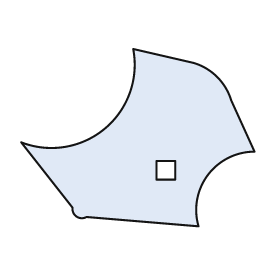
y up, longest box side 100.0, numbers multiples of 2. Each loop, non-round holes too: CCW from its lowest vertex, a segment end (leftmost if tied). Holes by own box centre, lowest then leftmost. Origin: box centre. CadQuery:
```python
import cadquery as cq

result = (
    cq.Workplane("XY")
    .moveTo(26.0, -38.0)
    .threePointArc((30.0, -16.0), (50.0, -6.0))
    .lineTo(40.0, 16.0)
    .threePointArc((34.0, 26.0), (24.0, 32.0))
    .lineTo(-2.0, 38.0)
    .threePointArc((-14.0, 4.0), (-50.0, -2.0))
    .lineTo(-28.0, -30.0)
    .threePointArc((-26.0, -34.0), (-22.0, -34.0))
    .close()
    .moveTo(8.0, -18.0)
    .lineTo(16.0, -18.0)
    .lineTo(16.0, -10.0)
    .lineTo(8.0, -10.0)
    .close()
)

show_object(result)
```